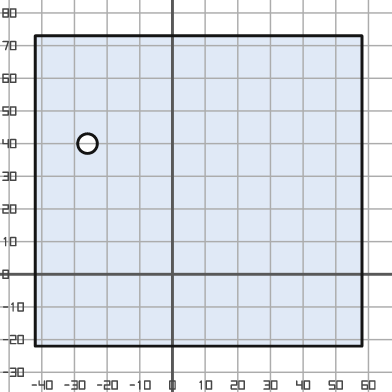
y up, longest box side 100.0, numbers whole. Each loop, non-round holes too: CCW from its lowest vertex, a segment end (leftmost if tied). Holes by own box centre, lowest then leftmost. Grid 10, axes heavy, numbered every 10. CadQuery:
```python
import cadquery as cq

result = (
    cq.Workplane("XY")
    .moveTo(-42.0, -22.0)
    .lineTo(58.0, -22.0)
    .lineTo(58.0, 73.0)
    .lineTo(-42.0, 73.0)
    .close()
    .moveTo(-26.0, 40.0)
    .circle(3.0)
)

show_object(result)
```